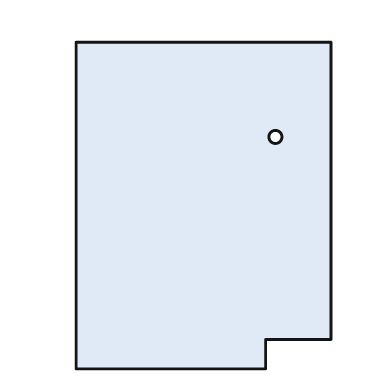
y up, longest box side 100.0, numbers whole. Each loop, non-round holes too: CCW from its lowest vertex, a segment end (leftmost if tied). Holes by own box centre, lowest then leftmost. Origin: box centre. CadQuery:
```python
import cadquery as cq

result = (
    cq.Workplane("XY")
    .moveTo(-39.0, -50.0)
    .lineTo(19.0, -50.0)
    .lineTo(19.0, -41.0)
    .lineTo(39.0, -41.0)
    .lineTo(39.0, 50.0)
    .lineTo(-39.0, 50.0)
    .close()
    .moveTo(22.0, 21.0)
    .circle(2.0)
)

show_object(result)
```